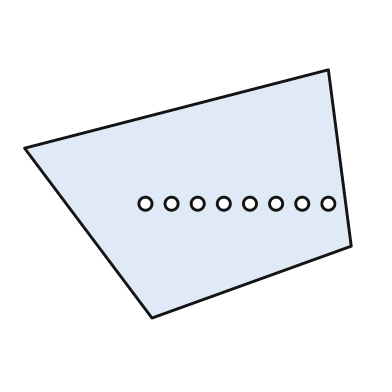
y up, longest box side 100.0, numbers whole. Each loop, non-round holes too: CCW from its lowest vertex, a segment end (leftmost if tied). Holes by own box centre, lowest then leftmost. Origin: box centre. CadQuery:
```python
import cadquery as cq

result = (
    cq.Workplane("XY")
    .moveTo(-11.0, -38.0)
    .lineTo(50.0, -16.0)
    .lineTo(43.0, 38.0)
    .lineTo(-50.0, 14.0)
    .close()
    .moveTo(-13.0, -3.0)
    .circle(2.0)
    .moveTo(-5.0, -3.0)
    .circle(2.0)
    .moveTo(3.0, -3.0)
    .circle(2.0)
    .moveTo(11.0, -3.0)
    .circle(2.0)
    .moveTo(19.0, -3.0)
    .circle(2.0)
    .moveTo(27.0, -3.0)
    .circle(2.0)
    .moveTo(35.0, -3.0)
    .circle(2.0)
    .moveTo(43.0, -3.0)
    .circle(2.0)
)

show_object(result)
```